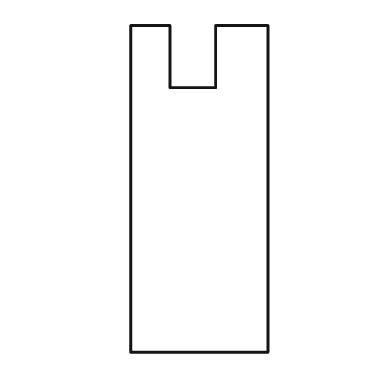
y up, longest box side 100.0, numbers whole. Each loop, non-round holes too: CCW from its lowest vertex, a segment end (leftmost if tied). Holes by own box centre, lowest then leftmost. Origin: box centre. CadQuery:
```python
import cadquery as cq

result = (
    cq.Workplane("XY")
    .moveTo(-21.0, -50.0)
    .lineTo(21.0, -50.0)
    .lineTo(21.0, 50.0)
    .lineTo(5.0, 50.0)
    .lineTo(5.0, 31.0)
    .lineTo(-9.0, 31.0)
    .lineTo(-9.0, 50.0)
    .lineTo(-21.0, 50.0)
    .close()
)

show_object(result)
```